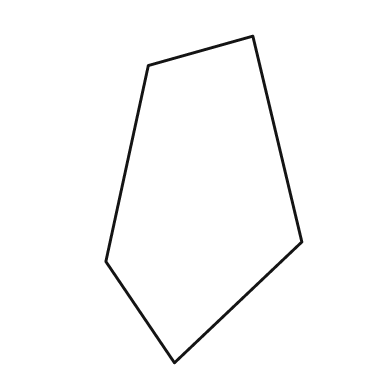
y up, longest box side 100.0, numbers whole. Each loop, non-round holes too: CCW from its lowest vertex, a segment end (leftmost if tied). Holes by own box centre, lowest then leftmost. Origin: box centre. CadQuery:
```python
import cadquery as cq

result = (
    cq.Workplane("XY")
    .moveTo(-9.0, -50.0)
    .lineTo(30.0, -13.0)
    .lineTo(15.0, 50.0)
    .lineTo(-17.0, 41.0)
    .lineTo(-30.0, -19.0)
    .close()
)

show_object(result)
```